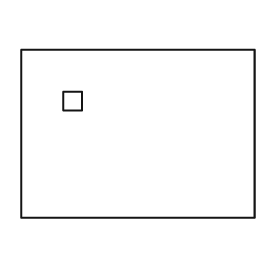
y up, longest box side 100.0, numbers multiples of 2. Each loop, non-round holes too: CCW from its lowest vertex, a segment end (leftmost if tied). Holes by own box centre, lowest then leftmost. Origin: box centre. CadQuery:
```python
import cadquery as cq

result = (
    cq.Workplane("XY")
    .moveTo(-50.0, -36.0)
    .lineTo(50.0, -36.0)
    .lineTo(50.0, 36.0)
    .lineTo(-50.0, 36.0)
    .close()
    .moveTo(-32.0, 10.0)
    .lineTo(-24.0, 10.0)
    .lineTo(-24.0, 18.0)
    .lineTo(-32.0, 18.0)
    .close()
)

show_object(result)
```